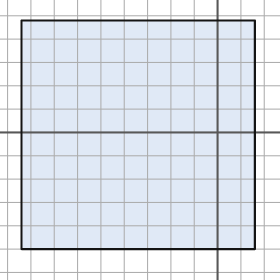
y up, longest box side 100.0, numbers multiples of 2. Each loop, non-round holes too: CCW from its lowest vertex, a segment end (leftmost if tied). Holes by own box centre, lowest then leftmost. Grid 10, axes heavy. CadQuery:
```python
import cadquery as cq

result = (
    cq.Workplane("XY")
    .moveTo(-84.0, -50.0)
    .lineTo(16.0, -50.0)
    .lineTo(16.0, 48.0)
    .lineTo(-84.0, 48.0)
    .close()
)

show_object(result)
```